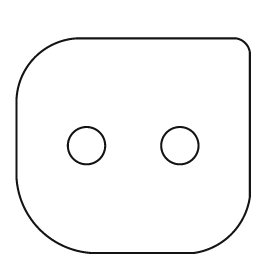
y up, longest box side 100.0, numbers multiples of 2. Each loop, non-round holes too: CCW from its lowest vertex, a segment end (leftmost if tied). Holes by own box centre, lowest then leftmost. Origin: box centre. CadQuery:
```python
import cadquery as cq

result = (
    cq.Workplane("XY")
    .moveTo(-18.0, -46.0)
    .lineTo(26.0, -46.0)
    .threePointArc((42.0, -38.0), (50.0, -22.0))
    .lineTo(50.0, 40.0)
    .threePointArc((48.0, 44.0), (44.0, 46.0))
    .lineTo(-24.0, 46.0)
    .threePointArc((-42.0, 38.0), (-50.0, 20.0))
    .lineTo(-50.0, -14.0)
    .threePointArc((-40.0, -36.0), (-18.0, -46.0))
    .close()
    .moveTo(-20.0, 0.0)
    .circle(8.0)
    .moveTo(20.0, 0.0)
    .circle(8.0)
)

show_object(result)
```